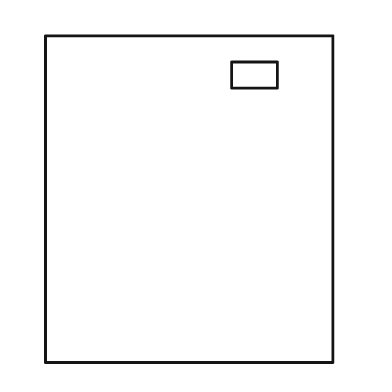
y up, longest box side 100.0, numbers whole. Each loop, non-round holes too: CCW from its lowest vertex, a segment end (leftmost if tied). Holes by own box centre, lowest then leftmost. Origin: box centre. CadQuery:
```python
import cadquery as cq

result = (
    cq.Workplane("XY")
    .moveTo(-44.0, -50.0)
    .lineTo(44.0, -50.0)
    .lineTo(44.0, 50.0)
    .lineTo(-44.0, 50.0)
    .close()
    .moveTo(13.0, 34.0)
    .lineTo(27.0, 34.0)
    .lineTo(27.0, 42.0)
    .lineTo(13.0, 42.0)
    .close()
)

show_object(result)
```